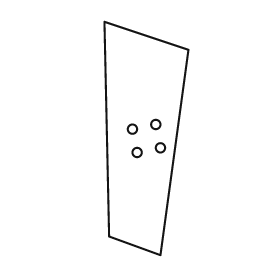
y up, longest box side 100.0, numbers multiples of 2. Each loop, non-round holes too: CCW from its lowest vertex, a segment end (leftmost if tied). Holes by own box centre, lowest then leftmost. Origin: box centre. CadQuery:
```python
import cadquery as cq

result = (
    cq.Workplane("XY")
    .moveTo(6.0, -50.0)
    .lineTo(18.0, 38.0)
    .lineTo(-18.0, 50.0)
    .lineTo(-16.0, -42.0)
    .close()
    .moveTo(-4.0, -6.0)
    .circle(2.0)
    .moveTo(6.0, -4.0)
    .circle(2.0)
    .moveTo(-6.0, 4.0)
    .circle(2.0)
    .moveTo(4.0, 6.0)
    .circle(2.0)
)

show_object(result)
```